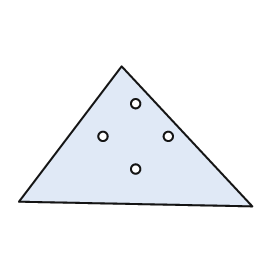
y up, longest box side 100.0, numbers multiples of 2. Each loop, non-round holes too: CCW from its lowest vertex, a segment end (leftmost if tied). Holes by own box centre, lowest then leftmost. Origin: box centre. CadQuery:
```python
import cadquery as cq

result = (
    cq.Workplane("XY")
    .moveTo(50.0, -30.0)
    .lineTo(-6.0, 30.0)
    .lineTo(-50.0, -28.0)
    .close()
    .moveTo(0.0, -14.0)
    .circle(2.0)
    .moveTo(-14.0, 0.0)
    .circle(2.0)
    .moveTo(14.0, 0.0)
    .circle(2.0)
    .moveTo(0.0, 14.0)
    .circle(2.0)
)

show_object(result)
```